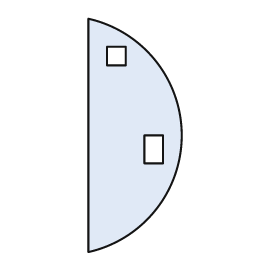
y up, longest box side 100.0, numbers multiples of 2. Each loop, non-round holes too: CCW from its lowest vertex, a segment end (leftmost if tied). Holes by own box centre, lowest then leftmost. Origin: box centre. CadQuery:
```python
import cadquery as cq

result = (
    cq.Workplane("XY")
    .moveTo(-20.0, -50.0)
    .threePointArc((20.0, 0.0), (-20.0, 50.0))
    .close()
    .moveTo(4.0, -12.0)
    .lineTo(12.0, -12.0)
    .lineTo(12.0, 0.0)
    .lineTo(4.0, 0.0)
    .close()
    .moveTo(-12.0, 30.0)
    .lineTo(-4.0, 30.0)
    .lineTo(-4.0, 38.0)
    .lineTo(-12.0, 38.0)
    .close()
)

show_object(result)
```